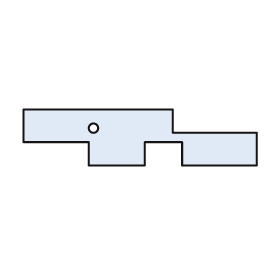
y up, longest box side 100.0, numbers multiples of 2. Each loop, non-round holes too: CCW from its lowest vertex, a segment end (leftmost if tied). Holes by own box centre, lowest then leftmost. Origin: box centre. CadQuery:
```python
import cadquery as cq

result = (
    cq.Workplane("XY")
    .moveTo(-22.0, -12.0)
    .lineTo(2.0, -12.0)
    .lineTo(2.0, -2.0)
    .lineTo(18.0, -2.0)
    .lineTo(18.0, -12.0)
    .lineTo(50.0, -12.0)
    .lineTo(50.0, 2.0)
    .lineTo(14.0, 2.0)
    .lineTo(14.0, 12.0)
    .lineTo(-50.0, 12.0)
    .lineTo(-50.0, -2.0)
    .lineTo(-22.0, -2.0)
    .close()
    .moveTo(-20.0, 4.0)
    .circle(2.0)
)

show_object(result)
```